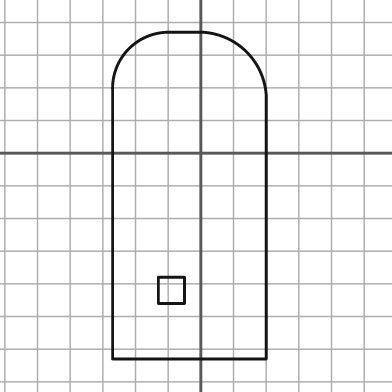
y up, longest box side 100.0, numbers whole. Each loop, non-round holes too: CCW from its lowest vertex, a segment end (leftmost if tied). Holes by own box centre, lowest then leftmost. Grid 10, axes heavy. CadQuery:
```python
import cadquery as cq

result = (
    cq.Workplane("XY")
    .moveTo(-27.0, -63.0)
    .lineTo(20.0, -63.0)
    .lineTo(20.0, 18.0)
    .threePointArc((14.0, 31.0), (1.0, 37.0))
    .lineTo(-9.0, 37.0)
    .threePointArc((-22.0, 32.0), (-27.0, 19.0))
    .close()
    .moveTo(-13.0, -46.0)
    .lineTo(-5.0, -46.0)
    .lineTo(-5.0, -38.0)
    .lineTo(-13.0, -38.0)
    .close()
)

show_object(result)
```